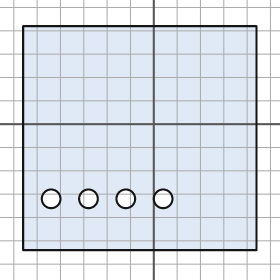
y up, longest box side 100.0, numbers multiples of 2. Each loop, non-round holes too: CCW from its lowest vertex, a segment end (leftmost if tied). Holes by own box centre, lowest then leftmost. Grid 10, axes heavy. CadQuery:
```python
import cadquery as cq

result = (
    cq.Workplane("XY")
    .moveTo(-56.0, -54.0)
    .lineTo(44.0, -54.0)
    .lineTo(44.0, 42.0)
    .lineTo(-56.0, 42.0)
    .close()
    .moveTo(-44.0, -32.0)
    .circle(4.0)
    .moveTo(-28.0, -32.0)
    .circle(4.0)
    .moveTo(-12.0, -32.0)
    .circle(4.0)
    .moveTo(4.0, -32.0)
    .circle(4.0)
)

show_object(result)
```